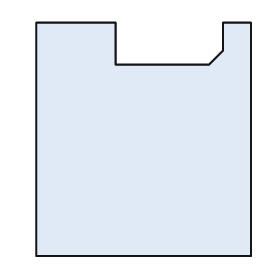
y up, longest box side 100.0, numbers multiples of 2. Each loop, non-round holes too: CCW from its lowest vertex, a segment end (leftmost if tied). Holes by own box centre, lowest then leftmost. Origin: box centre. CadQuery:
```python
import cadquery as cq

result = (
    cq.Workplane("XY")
    .moveTo(-46.0, -50.0)
    .lineTo(46.0, -50.0)
    .lineTo(46.0, 50.0)
    .lineTo(34.0, 50.0)
    .lineTo(34.0, 38.0)
    .lineTo(28.0, 32.0)
    .lineTo(-12.0, 32.0)
    .lineTo(-12.0, 50.0)
    .lineTo(-46.0, 50.0)
    .close()
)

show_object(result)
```